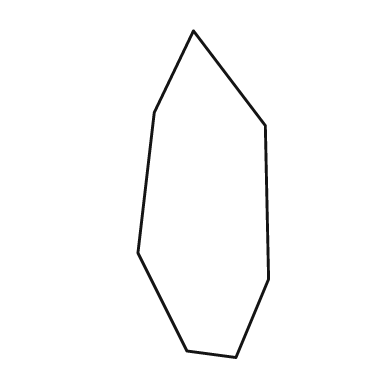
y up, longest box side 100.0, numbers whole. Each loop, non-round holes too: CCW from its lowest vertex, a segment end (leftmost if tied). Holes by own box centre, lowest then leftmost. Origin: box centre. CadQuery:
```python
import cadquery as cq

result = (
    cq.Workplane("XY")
    .moveTo(10.0, -50.0)
    .lineTo(20.0, -26.0)
    .lineTo(19.0, 21.0)
    .lineTo(-3.0, 50.0)
    .lineTo(-15.0, 25.0)
    .lineTo(-20.0, -18.0)
    .lineTo(-5.0, -48.0)
    .close()
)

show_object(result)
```